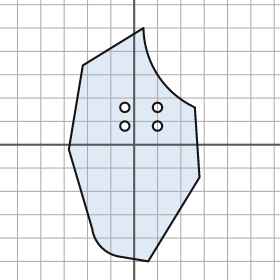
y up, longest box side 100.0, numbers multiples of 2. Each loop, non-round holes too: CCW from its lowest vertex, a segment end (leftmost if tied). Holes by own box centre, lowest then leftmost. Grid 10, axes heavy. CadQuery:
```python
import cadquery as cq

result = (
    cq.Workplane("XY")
    .moveTo(6.0, -50.0)
    .lineTo(28.0, -14.0)
    .lineTo(26.0, 16.0)
    .threePointArc((10.0, 30.0), (4.0, 50.0))
    .lineTo(-22.0, 34.0)
    .lineTo(-28.0, -2.0)
    .lineTo(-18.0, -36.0)
    .threePointArc((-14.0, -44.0), (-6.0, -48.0))
    .close()
    .moveTo(-4.0, 8.0)
    .circle(2.0)
    .moveTo(10.0, 8.0)
    .circle(2.0)
    .moveTo(-4.0, 16.0)
    .circle(2.0)
    .moveTo(10.0, 16.0)
    .circle(2.0)
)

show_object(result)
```